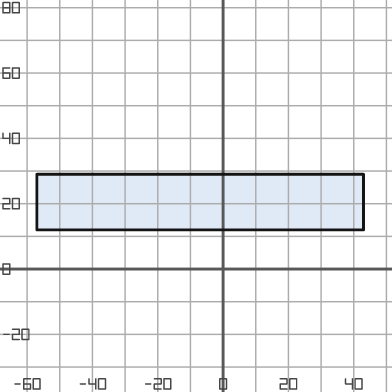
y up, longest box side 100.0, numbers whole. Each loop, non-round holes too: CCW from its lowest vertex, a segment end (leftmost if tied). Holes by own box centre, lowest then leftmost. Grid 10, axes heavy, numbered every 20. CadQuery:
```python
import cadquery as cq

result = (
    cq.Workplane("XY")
    .moveTo(-57.0, 12.0)
    .lineTo(43.0, 12.0)
    .lineTo(43.0, 29.0)
    .lineTo(-57.0, 29.0)
    .close()
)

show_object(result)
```